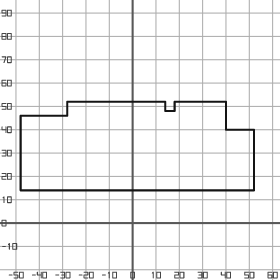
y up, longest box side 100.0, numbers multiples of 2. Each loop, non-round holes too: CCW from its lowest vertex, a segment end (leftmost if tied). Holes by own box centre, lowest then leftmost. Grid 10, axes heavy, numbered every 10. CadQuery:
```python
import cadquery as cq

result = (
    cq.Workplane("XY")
    .moveTo(-48.0, 14.0)
    .lineTo(52.0, 14.0)
    .lineTo(52.0, 40.0)
    .lineTo(40.0, 40.0)
    .lineTo(40.0, 52.0)
    .lineTo(18.0, 52.0)
    .lineTo(18.0, 48.0)
    .lineTo(14.0, 48.0)
    .lineTo(14.0, 52.0)
    .lineTo(-28.0, 52.0)
    .lineTo(-28.0, 46.0)
    .lineTo(-48.0, 46.0)
    .close()
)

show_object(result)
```